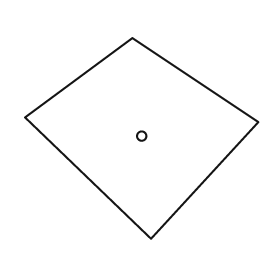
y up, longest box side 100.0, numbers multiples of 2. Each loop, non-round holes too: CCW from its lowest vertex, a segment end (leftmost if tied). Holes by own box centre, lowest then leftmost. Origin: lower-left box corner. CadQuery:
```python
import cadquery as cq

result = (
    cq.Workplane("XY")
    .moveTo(54.0, 0.0)
    .lineTo(100.0, 50.0)
    .lineTo(46.0, 86.0)
    .lineTo(0.0, 52.0)
    .close()
    .moveTo(50.0, 44.0)
    .circle(2.0)
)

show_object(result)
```